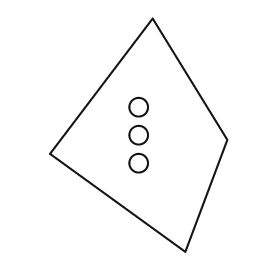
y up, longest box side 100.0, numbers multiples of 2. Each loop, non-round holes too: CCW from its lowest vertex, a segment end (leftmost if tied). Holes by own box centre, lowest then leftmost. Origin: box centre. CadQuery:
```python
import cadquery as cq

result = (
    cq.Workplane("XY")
    .moveTo(20.0, -50.0)
    .lineTo(38.0, -2.0)
    .lineTo(6.0, 50.0)
    .lineTo(-38.0, -8.0)
    .close()
    .moveTo(0.0, -12.0)
    .circle(4.0)
    .moveTo(0.0, 0.0)
    .circle(4.0)
    .moveTo(0.0, 12.0)
    .circle(4.0)
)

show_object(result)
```